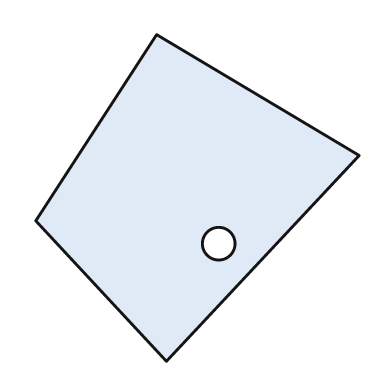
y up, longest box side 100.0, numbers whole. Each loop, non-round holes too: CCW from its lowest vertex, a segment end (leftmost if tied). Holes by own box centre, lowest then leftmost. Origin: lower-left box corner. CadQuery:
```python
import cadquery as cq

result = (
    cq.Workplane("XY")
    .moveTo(40.0, 0.0)
    .lineTo(99.0, 63.0)
    .lineTo(37.0, 100.0)
    .lineTo(0.0, 43.0)
    .close()
    .moveTo(56.0, 36.0)
    .circle(5.0)
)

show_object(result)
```